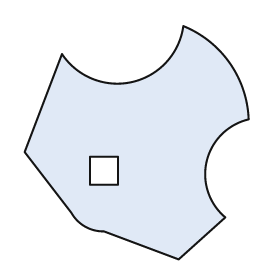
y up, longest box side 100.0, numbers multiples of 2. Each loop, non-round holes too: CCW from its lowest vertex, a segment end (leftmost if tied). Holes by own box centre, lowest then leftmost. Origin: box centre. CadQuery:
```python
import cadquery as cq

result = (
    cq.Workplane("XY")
    .moveTo(18.0, -50.0)
    .lineTo(38.0, -32.0)
    .threePointArc((30.0, -8.0), (48.0, 10.0))
    .threePointArc((40.0, 34.0), (20.0, 50.0))
    .threePointArc((-2.0, 26.0), (-32.0, 38.0))
    .lineTo(-48.0, -4.0)
    .lineTo(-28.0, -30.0)
    .threePointArc((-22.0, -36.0), (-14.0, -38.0))
    .close()
    .moveTo(-20.0, -18.0)
    .lineTo(-8.0, -18.0)
    .lineTo(-8.0, -6.0)
    .lineTo(-20.0, -6.0)
    .close()
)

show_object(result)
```